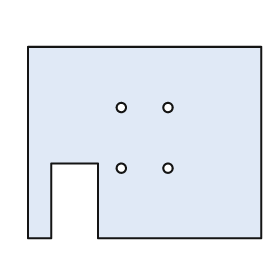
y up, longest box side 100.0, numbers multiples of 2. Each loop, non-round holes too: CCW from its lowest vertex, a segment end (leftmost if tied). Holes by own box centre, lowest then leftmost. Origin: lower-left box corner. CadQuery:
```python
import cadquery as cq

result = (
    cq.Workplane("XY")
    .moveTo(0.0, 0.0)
    .lineTo(10.0, 0.0)
    .lineTo(10.0, 32.0)
    .lineTo(30.0, 32.0)
    .lineTo(30.0, 0.0)
    .lineTo(100.0, 0.0)
    .lineTo(100.0, 82.0)
    .lineTo(0.0, 82.0)
    .close()
    .moveTo(40.0, 30.0)
    .circle(2.0)
    .moveTo(60.0, 30.0)
    .circle(2.0)
    .moveTo(40.0, 56.0)
    .circle(2.0)
    .moveTo(60.0, 56.0)
    .circle(2.0)
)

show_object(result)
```